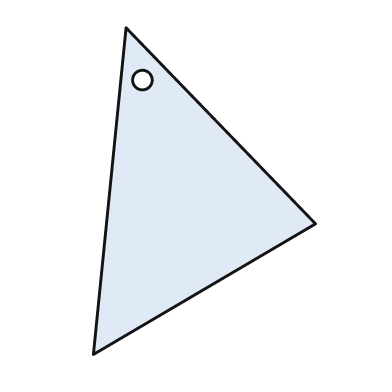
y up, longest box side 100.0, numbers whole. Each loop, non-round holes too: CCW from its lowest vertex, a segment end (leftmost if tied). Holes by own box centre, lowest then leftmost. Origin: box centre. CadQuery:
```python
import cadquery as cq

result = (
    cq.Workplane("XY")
    .moveTo(-34.0, -50.0)
    .lineTo(34.0, -10.0)
    .lineTo(-24.0, 50.0)
    .close()
    .moveTo(-19.0, 34.0)
    .circle(3.0)
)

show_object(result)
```